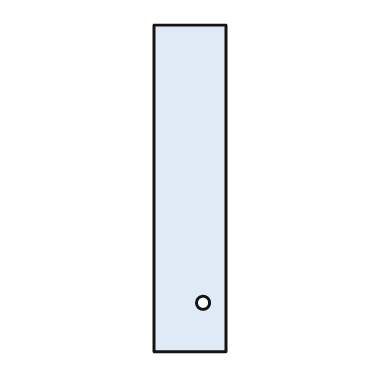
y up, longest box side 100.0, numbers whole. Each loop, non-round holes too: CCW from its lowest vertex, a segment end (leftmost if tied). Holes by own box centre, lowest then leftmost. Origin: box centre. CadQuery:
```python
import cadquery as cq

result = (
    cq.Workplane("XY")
    .moveTo(-11.0, -50.0)
    .lineTo(11.0, -50.0)
    .lineTo(11.0, 50.0)
    .lineTo(-11.0, 50.0)
    .close()
    .moveTo(4.0, -35.0)
    .circle(2.0)
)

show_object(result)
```